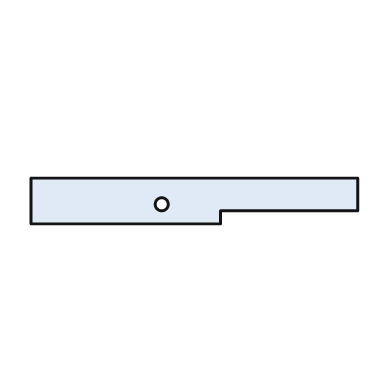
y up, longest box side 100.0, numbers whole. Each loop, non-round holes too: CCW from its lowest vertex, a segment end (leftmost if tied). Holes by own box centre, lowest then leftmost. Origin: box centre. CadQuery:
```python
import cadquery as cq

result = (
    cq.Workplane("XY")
    .moveTo(-50.0, -7.0)
    .lineTo(8.0, -7.0)
    .lineTo(8.0, -3.0)
    .lineTo(50.0, -3.0)
    .lineTo(50.0, 7.0)
    .lineTo(-50.0, 7.0)
    .close()
    .moveTo(-10.0, -1.0)
    .circle(2.0)
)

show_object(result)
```